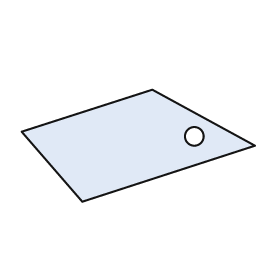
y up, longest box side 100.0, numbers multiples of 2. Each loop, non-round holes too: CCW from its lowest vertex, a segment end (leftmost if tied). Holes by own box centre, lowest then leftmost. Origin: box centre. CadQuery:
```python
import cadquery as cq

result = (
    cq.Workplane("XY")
    .moveTo(-24.0, -24.0)
    .lineTo(50.0, 0.0)
    .lineTo(6.0, 24.0)
    .lineTo(-50.0, 6.0)
    .close()
    .moveTo(24.0, 4.0)
    .circle(4.0)
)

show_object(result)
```